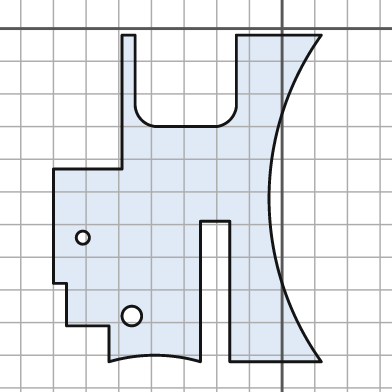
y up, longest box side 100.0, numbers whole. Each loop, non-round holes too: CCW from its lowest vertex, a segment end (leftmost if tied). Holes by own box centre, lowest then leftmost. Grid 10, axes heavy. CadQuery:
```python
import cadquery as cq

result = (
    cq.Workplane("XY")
    .moveTo(-53.0, -102.0)
    .threePointArc((-39.0, -100.0), (-25.0, -102.0))
    .lineTo(-25.0, -59.0)
    .lineTo(-16.0, -59.0)
    .lineTo(-16.0, -102.0)
    .lineTo(12.0, -102.0)
    .threePointArc((-4.0, -52.0), (12.0, -2.0))
    .lineTo(-14.0, -2.0)
    .lineTo(-14.0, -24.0)
    .threePointArc((-16.0, -28.0), (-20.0, -30.0))
    .lineTo(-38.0, -30.0)
    .threePointArc((-43.0, -28.0), (-45.0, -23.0))
    .lineTo(-45.0, -2.0)
    .lineTo(-49.0, -2.0)
    .lineTo(-49.0, -43.0)
    .lineTo(-70.0, -43.0)
    .lineTo(-70.0, -78.0)
    .lineTo(-66.0, -78.0)
    .lineTo(-66.0, -91.0)
    .lineTo(-53.0, -91.0)
    .close()
    .moveTo(-46.0, -88.0)
    .circle(3.0)
    .moveTo(-61.0, -64.0)
    .circle(2.0)
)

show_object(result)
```